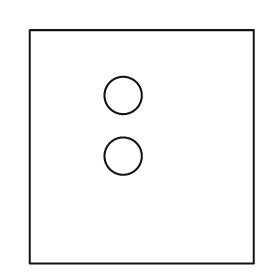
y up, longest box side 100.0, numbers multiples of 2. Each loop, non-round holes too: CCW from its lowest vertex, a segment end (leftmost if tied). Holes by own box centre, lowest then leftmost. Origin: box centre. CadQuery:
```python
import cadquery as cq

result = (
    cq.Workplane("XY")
    .moveTo(-48.0, -50.0)
    .lineTo(48.0, -50.0)
    .lineTo(48.0, 50.0)
    .lineTo(-48.0, 50.0)
    .close()
    .moveTo(-8.0, -4.0)
    .circle(8.0)
    .moveTo(-8.0, 22.0)
    .circle(8.0)
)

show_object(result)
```